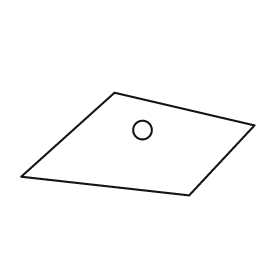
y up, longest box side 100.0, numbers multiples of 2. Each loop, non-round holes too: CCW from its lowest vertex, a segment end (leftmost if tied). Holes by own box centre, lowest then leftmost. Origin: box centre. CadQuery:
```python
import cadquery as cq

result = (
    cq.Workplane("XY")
    .moveTo(22.0, -22.0)
    .lineTo(50.0, 8.0)
    .lineTo(-10.0, 22.0)
    .lineTo(-50.0, -14.0)
    .close()
    .moveTo(2.0, 6.0)
    .circle(4.0)
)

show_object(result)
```